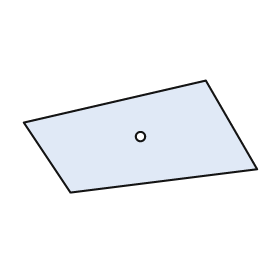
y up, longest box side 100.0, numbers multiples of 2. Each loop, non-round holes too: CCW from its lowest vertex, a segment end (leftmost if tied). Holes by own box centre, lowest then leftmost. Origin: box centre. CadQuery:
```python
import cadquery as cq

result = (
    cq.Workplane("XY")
    .moveTo(-30.0, -24.0)
    .lineTo(50.0, -14.0)
    .lineTo(28.0, 24.0)
    .lineTo(-50.0, 6.0)
    .close()
    .moveTo(0.0, 0.0)
    .circle(2.0)
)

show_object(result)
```